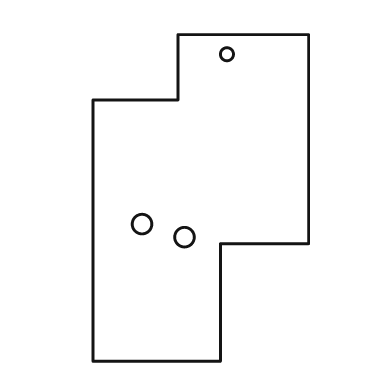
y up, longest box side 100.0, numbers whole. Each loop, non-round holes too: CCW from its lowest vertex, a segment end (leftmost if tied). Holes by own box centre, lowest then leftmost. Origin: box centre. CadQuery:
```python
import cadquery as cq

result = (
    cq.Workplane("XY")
    .moveTo(-33.0, -50.0)
    .lineTo(6.0, -50.0)
    .lineTo(6.0, -14.0)
    .lineTo(33.0, -14.0)
    .lineTo(33.0, 50.0)
    .lineTo(-7.0, 50.0)
    .lineTo(-7.0, 30.0)
    .lineTo(-33.0, 30.0)
    .close()
    .moveTo(-5.0, -12.0)
    .circle(3.0)
    .moveTo(-18.0, -8.0)
    .circle(3.0)
    .moveTo(8.0, 44.0)
    .circle(2.0)
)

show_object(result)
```